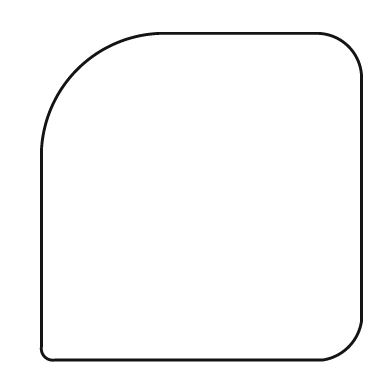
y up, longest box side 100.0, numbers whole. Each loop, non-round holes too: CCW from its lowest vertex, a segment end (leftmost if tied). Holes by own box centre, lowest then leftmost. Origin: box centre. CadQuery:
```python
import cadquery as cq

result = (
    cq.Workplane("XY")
    .moveTo(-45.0, -50.0)
    .lineTo(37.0, -50.0)
    .threePointArc((45.0, -46.0), (49.0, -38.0))
    .lineTo(49.0, 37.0)
    .threePointArc((45.0, 46.0), (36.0, 50.0))
    .lineTo(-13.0, 50.0)
    .threePointArc((-38.0, 39.0), (-49.0, 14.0))
    .lineTo(-49.0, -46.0)
    .threePointArc((-48.0, -49.0), (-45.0, -50.0))
    .close()
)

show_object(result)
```